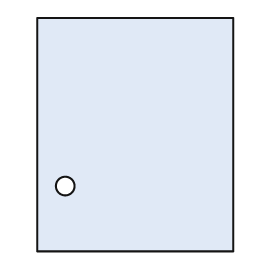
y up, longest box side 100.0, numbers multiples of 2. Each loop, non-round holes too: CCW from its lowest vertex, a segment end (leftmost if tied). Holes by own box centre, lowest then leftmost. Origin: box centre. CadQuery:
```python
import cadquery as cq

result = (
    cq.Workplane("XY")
    .moveTo(-42.0, -50.0)
    .lineTo(42.0, -50.0)
    .lineTo(42.0, 50.0)
    .lineTo(-42.0, 50.0)
    .close()
    .moveTo(-30.0, -22.0)
    .circle(4.0)
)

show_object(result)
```